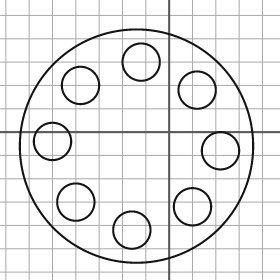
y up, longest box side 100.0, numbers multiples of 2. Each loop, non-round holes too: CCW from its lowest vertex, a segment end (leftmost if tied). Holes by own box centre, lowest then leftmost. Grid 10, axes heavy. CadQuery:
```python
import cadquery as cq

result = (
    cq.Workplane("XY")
    .moveTo(-14.0, -6.0)
    .circle(50.0)
    .moveTo(-16.0, -42.0)
    .circle(8.0)
    .moveTo(10.0, -32.0)
    .circle(8.0)
    .moveTo(-40.0, -30.0)
    .circle(8.0)
    .moveTo(22.0, -8.0)
    .circle(8.0)
    .moveTo(-50.0, -4.0)
    .circle(8.0)
    .moveTo(12.0, 18.0)
    .circle(8.0)
    .moveTo(-38.0, 20.0)
    .circle(8.0)
    .moveTo(-12.0, 30.0)
    .circle(8.0)
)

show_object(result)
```